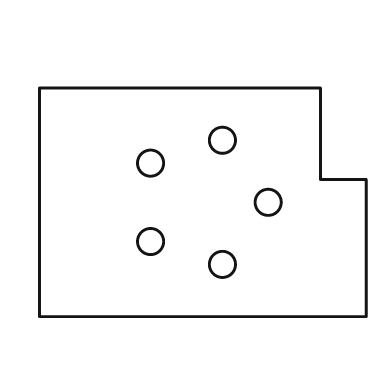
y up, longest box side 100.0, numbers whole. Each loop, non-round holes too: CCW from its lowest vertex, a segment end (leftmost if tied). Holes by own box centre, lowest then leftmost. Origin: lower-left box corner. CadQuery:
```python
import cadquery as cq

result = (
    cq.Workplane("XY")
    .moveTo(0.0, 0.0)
    .lineTo(100.0, 0.0)
    .lineTo(100.0, 42.0)
    .lineTo(86.0, 42.0)
    .lineTo(86.0, 70.0)
    .lineTo(0.0, 70.0)
    .close()
    .moveTo(56.0, 16.0)
    .circle(4.0)
    .moveTo(34.0, 23.0)
    .circle(4.0)
    .moveTo(70.0, 35.0)
    .circle(4.0)
    .moveTo(34.0, 47.0)
    .circle(4.0)
    .moveTo(56.0, 54.0)
    .circle(4.0)
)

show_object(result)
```